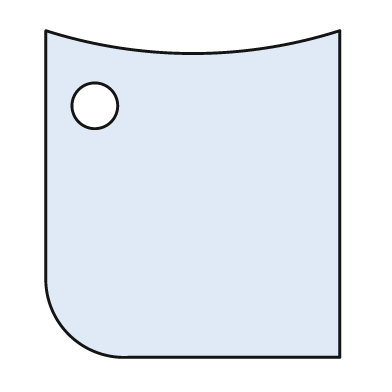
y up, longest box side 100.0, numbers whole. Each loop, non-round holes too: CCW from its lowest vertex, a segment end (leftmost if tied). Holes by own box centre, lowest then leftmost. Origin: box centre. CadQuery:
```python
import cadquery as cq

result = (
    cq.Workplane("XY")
    .moveTo(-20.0, -50.0)
    .lineTo(45.0, -50.0)
    .lineTo(45.0, 50.0)
    .threePointArc((0.0, 43.0), (-45.0, 50.0))
    .lineTo(-45.0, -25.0)
    .threePointArc((-38.0, -43.0), (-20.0, -50.0))
    .close()
    .moveTo(-30.0, 27.0)
    .circle(7.0)
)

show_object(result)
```